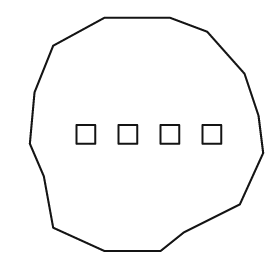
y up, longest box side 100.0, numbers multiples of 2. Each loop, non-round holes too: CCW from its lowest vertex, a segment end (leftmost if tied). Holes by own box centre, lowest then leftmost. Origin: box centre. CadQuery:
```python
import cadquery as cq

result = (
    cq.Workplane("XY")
    .moveTo(-18.0, -50.0)
    .lineTo(6.0, -50.0)
    .lineTo(16.0, -42.0)
    .lineTo(40.0, -30.0)
    .lineTo(50.0, -8.0)
    .lineTo(48.0, 8.0)
    .lineTo(42.0, 26.0)
    .lineTo(26.0, 44.0)
    .lineTo(10.0, 50.0)
    .lineTo(-18.0, 50.0)
    .lineTo(-40.0, 38.0)
    .lineTo(-48.0, 18.0)
    .lineTo(-50.0, -4.0)
    .lineTo(-44.0, -18.0)
    .lineTo(-40.0, -40.0)
    .close()
    .moveTo(-30.0, -4.0)
    .lineTo(-22.0, -4.0)
    .lineTo(-22.0, 4.0)
    .lineTo(-30.0, 4.0)
    .close()
    .moveTo(-12.0, -4.0)
    .lineTo(-4.0, -4.0)
    .lineTo(-4.0, 4.0)
    .lineTo(-12.0, 4.0)
    .close()
    .moveTo(6.0, -4.0)
    .lineTo(14.0, -4.0)
    .lineTo(14.0, 4.0)
    .lineTo(6.0, 4.0)
    .close()
    .moveTo(24.0, -4.0)
    .lineTo(32.0, -4.0)
    .lineTo(32.0, 4.0)
    .lineTo(24.0, 4.0)
    .close()
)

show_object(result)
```